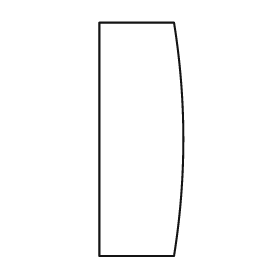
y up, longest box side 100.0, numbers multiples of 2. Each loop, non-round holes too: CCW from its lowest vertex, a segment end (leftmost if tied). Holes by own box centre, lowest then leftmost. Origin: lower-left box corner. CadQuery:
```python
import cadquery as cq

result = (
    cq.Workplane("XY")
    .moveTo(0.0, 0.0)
    .lineTo(32.0, 0.0)
    .threePointArc((36.0, 50.0), (32.0, 100.0))
    .lineTo(0.0, 100.0)
    .close()
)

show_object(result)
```